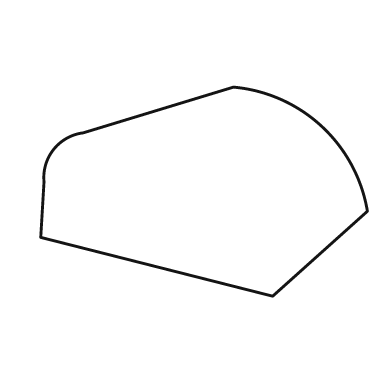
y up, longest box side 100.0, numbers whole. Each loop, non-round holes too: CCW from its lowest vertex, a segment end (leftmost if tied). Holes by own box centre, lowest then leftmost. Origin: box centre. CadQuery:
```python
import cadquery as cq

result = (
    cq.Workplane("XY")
    .moveTo(21.0, -32.0)
    .lineTo(50.0, -6.0)
    .threePointArc((36.0, 20.0), (9.0, 32.0))
    .lineTo(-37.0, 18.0)
    .threePointArc((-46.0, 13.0), (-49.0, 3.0))
    .lineTo(-50.0, -14.0)
    .close()
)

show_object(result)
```